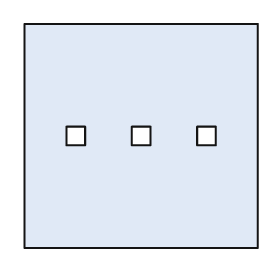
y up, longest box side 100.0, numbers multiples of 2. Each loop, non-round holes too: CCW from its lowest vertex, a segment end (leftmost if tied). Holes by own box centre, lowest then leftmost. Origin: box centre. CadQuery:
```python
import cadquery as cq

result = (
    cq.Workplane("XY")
    .moveTo(-50.0, -48.0)
    .lineTo(50.0, -48.0)
    .lineTo(50.0, 48.0)
    .lineTo(-50.0, 48.0)
    .close()
    .moveTo(-32.0, -4.0)
    .lineTo(-24.0, -4.0)
    .lineTo(-24.0, 4.0)
    .lineTo(-32.0, 4.0)
    .close()
    .moveTo(-4.0, -4.0)
    .lineTo(4.0, -4.0)
    .lineTo(4.0, 4.0)
    .lineTo(-4.0, 4.0)
    .close()
    .moveTo(24.0, -4.0)
    .lineTo(32.0, -4.0)
    .lineTo(32.0, 4.0)
    .lineTo(24.0, 4.0)
    .close()
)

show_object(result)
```